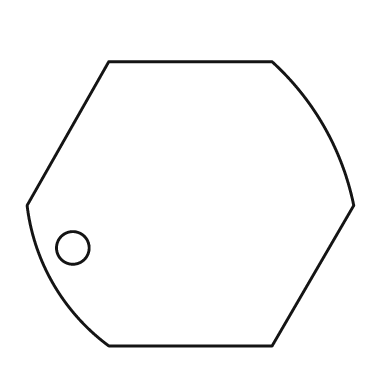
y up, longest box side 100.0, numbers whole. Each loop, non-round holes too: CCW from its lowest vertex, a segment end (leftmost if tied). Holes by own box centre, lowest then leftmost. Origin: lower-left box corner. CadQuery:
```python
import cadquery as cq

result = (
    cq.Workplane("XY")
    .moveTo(25.0, 0.0)
    .lineTo(75.0, 0.0)
    .lineTo(100.0, 43.0)
    .threePointArc((91.0, 67.0), (75.0, 87.0))
    .lineTo(25.0, 87.0)
    .lineTo(0.0, 43.0)
    .threePointArc((8.0, 19.0), (25.0, 0.0))
    .close()
    .moveTo(14.0, 30.0)
    .circle(5.0)
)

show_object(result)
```